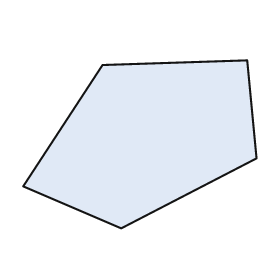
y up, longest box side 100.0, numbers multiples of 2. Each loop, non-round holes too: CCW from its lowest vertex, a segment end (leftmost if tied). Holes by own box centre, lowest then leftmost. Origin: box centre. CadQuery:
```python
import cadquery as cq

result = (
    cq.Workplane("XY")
    .moveTo(-8.0, -36.0)
    .lineTo(50.0, -6.0)
    .lineTo(46.0, 36.0)
    .lineTo(-16.0, 34.0)
    .lineTo(-50.0, -18.0)
    .close()
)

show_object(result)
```